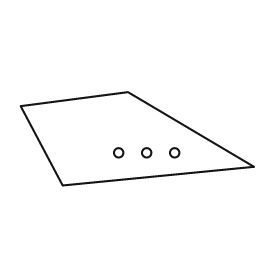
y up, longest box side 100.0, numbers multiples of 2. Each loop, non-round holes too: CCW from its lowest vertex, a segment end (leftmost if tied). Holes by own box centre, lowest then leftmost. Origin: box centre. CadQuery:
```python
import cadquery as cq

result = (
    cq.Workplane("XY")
    .moveTo(-32.0, -20.0)
    .lineTo(50.0, -12.0)
    .lineTo(-4.0, 20.0)
    .lineTo(-50.0, 14.0)
    .close()
    .moveTo(-8.0, -6.0)
    .circle(2.0)
    .moveTo(4.0, -6.0)
    .circle(2.0)
    .moveTo(16.0, -6.0)
    .circle(2.0)
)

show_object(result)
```